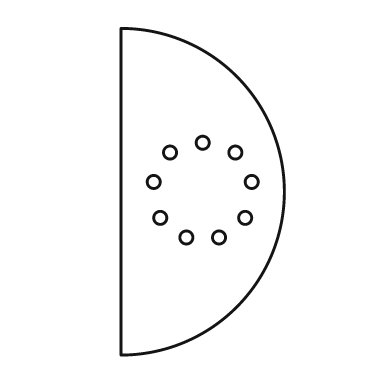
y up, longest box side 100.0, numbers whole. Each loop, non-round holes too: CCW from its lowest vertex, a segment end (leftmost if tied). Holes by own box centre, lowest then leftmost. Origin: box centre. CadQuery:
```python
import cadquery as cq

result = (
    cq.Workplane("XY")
    .moveTo(-25.0, -50.0)
    .threePointArc((25.0, 0.0), (-25.0, 50.0))
    .close()
    .moveTo(-5.0, -14.0)
    .circle(2.0)
    .moveTo(5.0, -14.0)
    .circle(2.0)
    .moveTo(-13.0, -8.0)
    .circle(2.0)
    .moveTo(13.0, -8.0)
    .circle(2.0)
    .moveTo(-15.0, 3.0)
    .circle(2.0)
    .moveTo(15.0, 3.0)
    .circle(2.0)
    .moveTo(-10.0, 12.0)
    .circle(2.0)
    .moveTo(10.0, 12.0)
    .circle(2.0)
    .moveTo(0.0, 15.0)
    .circle(2.0)
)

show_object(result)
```